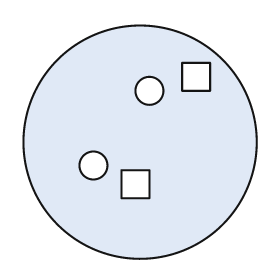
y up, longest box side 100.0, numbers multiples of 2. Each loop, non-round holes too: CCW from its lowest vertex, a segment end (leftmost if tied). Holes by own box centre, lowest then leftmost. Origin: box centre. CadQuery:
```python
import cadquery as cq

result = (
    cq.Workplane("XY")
    .moveTo(0.0, 0.0)
    .circle(50.0)
    .moveTo(-8.0, -24.0)
    .lineTo(4.0, -24.0)
    .lineTo(4.0, -12.0)
    .lineTo(-8.0, -12.0)
    .close()
    .moveTo(-20.0, -10.0)
    .circle(6.0)
    .moveTo(4.0, 22.0)
    .circle(6.0)
    .moveTo(18.0, 22.0)
    .lineTo(30.0, 22.0)
    .lineTo(30.0, 34.0)
    .lineTo(18.0, 34.0)
    .close()
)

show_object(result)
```